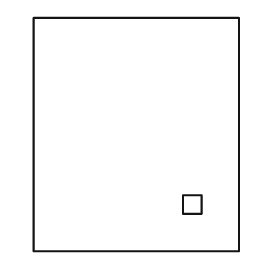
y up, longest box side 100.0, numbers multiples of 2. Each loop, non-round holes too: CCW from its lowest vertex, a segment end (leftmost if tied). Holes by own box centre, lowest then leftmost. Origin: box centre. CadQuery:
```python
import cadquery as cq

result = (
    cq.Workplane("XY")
    .moveTo(-44.0, -50.0)
    .lineTo(44.0, -50.0)
    .lineTo(44.0, 50.0)
    .lineTo(-44.0, 50.0)
    .close()
    .moveTo(20.0, -34.0)
    .lineTo(28.0, -34.0)
    .lineTo(28.0, -26.0)
    .lineTo(20.0, -26.0)
    .close()
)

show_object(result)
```